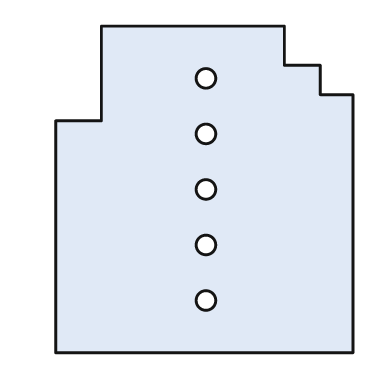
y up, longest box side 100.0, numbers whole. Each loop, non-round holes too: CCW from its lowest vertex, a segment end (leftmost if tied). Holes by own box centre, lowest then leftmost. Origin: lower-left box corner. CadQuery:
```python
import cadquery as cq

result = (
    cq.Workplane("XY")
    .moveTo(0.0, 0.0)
    .lineTo(91.0, 0.0)
    .lineTo(91.0, 79.0)
    .lineTo(81.0, 79.0)
    .lineTo(81.0, 88.0)
    .lineTo(70.0, 88.0)
    .lineTo(70.0, 100.0)
    .lineTo(14.0, 100.0)
    .lineTo(14.0, 71.0)
    .lineTo(0.0, 71.0)
    .close()
    .moveTo(46.0, 16.0)
    .circle(3.0)
    .moveTo(46.0, 33.0)
    .circle(3.0)
    .moveTo(46.0, 50.0)
    .circle(3.0)
    .moveTo(46.0, 67.0)
    .circle(3.0)
    .moveTo(46.0, 84.0)
    .circle(3.0)
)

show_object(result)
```